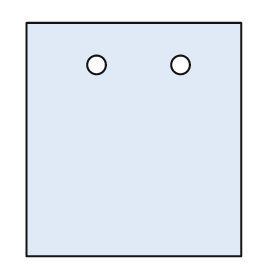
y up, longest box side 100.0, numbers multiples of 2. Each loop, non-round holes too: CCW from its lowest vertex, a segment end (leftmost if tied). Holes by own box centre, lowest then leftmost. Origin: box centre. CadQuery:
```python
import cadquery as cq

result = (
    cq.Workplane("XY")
    .moveTo(-46.0, -50.0)
    .lineTo(46.0, -50.0)
    .lineTo(46.0, 50.0)
    .lineTo(-46.0, 50.0)
    .close()
    .moveTo(-16.0, 32.0)
    .circle(4.0)
    .moveTo(20.0, 32.0)
    .circle(4.0)
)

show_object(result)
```